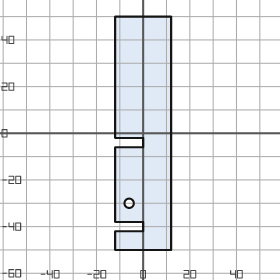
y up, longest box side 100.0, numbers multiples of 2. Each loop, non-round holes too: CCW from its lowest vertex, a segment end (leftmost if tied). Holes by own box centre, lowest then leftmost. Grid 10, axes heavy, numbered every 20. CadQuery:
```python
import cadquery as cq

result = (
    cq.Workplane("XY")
    .moveTo(-12.0, -50.0)
    .lineTo(12.0, -50.0)
    .lineTo(12.0, 50.0)
    .lineTo(-12.0, 50.0)
    .lineTo(-12.0, -2.0)
    .lineTo(0.0, -2.0)
    .lineTo(0.0, -6.0)
    .lineTo(-12.0, -6.0)
    .lineTo(-12.0, -38.0)
    .lineTo(0.0, -38.0)
    .lineTo(0.0, -42.0)
    .lineTo(-12.0, -42.0)
    .close()
    .moveTo(-6.0, -30.0)
    .circle(2.0)
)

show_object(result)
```